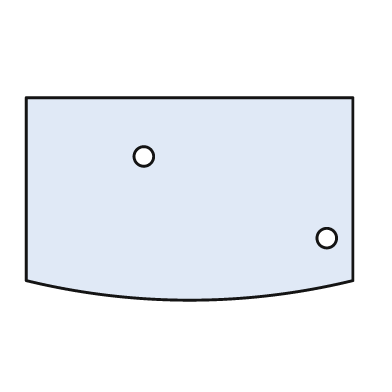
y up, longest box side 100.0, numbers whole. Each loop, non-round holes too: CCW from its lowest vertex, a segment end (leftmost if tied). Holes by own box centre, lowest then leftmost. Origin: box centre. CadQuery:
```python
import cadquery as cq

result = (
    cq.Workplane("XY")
    .moveTo(-50.0, -25.0)
    .threePointArc((0.0, -31.0), (50.0, -25.0))
    .lineTo(50.0, 31.0)
    .lineTo(-50.0, 31.0)
    .close()
    .moveTo(42.0, -12.0)
    .circle(3.0)
    .moveTo(-14.0, 13.0)
    .circle(3.0)
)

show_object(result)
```